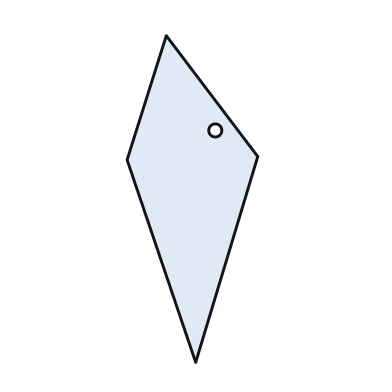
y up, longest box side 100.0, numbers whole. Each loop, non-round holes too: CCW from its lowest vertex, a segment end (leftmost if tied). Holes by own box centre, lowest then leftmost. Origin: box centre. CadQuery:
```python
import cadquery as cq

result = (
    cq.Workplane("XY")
    .moveTo(1.0, -50.0)
    .lineTo(20.0, 13.0)
    .lineTo(-8.0, 50.0)
    .lineTo(-20.0, 12.0)
    .close()
    .moveTo(7.0, 21.0)
    .circle(2.0)
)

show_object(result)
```